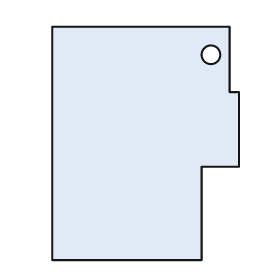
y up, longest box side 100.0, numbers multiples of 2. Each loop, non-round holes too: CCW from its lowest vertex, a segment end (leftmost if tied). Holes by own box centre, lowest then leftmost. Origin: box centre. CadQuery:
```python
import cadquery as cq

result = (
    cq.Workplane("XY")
    .moveTo(-40.0, -50.0)
    .lineTo(24.0, -50.0)
    .lineTo(24.0, -10.0)
    .lineTo(40.0, -10.0)
    .lineTo(40.0, 22.0)
    .lineTo(36.0, 22.0)
    .lineTo(36.0, 50.0)
    .lineTo(-40.0, 50.0)
    .close()
    .moveTo(28.0, 38.0)
    .circle(4.0)
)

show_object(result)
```